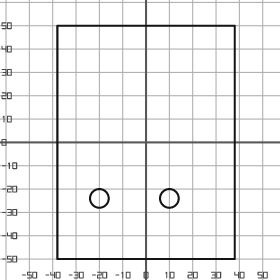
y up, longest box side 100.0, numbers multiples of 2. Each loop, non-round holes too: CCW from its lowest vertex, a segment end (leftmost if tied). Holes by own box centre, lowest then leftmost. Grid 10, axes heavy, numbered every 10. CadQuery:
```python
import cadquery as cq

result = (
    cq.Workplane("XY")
    .moveTo(-38.0, -50.0)
    .lineTo(38.0, -50.0)
    .lineTo(38.0, 50.0)
    .lineTo(-38.0, 50.0)
    .close()
    .moveTo(-20.0, -24.0)
    .circle(4.0)
    .moveTo(10.0, -24.0)
    .circle(4.0)
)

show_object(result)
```